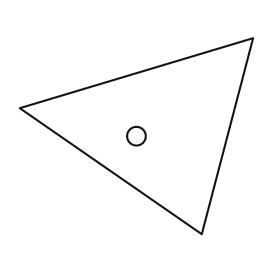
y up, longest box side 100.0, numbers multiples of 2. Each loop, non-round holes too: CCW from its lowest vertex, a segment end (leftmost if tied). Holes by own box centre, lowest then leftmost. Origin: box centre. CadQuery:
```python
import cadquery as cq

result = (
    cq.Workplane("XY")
    .moveTo(28.0, -42.0)
    .lineTo(50.0, 42.0)
    .lineTo(-50.0, 12.0)
    .close()
    .moveTo(0.0, 0.0)
    .circle(4.0)
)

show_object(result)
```